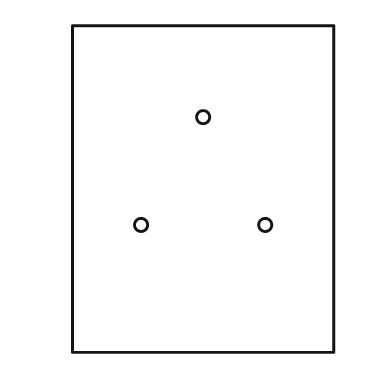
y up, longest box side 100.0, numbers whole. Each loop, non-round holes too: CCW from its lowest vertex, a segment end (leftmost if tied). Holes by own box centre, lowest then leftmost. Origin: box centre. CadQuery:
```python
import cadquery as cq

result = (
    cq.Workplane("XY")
    .moveTo(-40.0, -50.0)
    .lineTo(40.0, -50.0)
    .lineTo(40.0, 50.0)
    .lineTo(-40.0, 50.0)
    .close()
    .moveTo(-19.0, -11.0)
    .circle(2.0)
    .moveTo(19.0, -11.0)
    .circle(2.0)
    .moveTo(0.0, 22.0)
    .circle(2.0)
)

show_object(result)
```